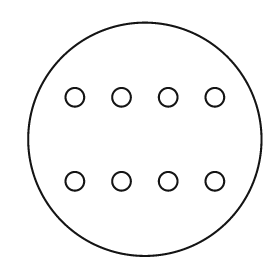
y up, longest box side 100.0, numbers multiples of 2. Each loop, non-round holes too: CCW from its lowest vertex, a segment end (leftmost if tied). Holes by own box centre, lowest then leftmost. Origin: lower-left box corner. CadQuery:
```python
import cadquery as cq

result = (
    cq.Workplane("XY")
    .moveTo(50.0, 50.0)
    .circle(50.0)
    .moveTo(20.0, 32.0)
    .circle(4.0)
    .moveTo(40.0, 32.0)
    .circle(4.0)
    .moveTo(60.0, 32.0)
    .circle(4.0)
    .moveTo(80.0, 32.0)
    .circle(4.0)
    .moveTo(20.0, 68.0)
    .circle(4.0)
    .moveTo(40.0, 68.0)
    .circle(4.0)
    .moveTo(60.0, 68.0)
    .circle(4.0)
    .moveTo(80.0, 68.0)
    .circle(4.0)
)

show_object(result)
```